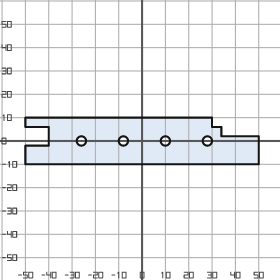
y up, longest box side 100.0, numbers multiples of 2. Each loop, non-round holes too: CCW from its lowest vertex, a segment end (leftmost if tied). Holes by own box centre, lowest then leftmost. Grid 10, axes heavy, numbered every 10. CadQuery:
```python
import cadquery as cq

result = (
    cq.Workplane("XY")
    .moveTo(-50.0, -10.0)
    .lineTo(50.0, -10.0)
    .lineTo(50.0, 2.0)
    .lineTo(34.0, 2.0)
    .lineTo(34.0, 6.0)
    .lineTo(30.0, 6.0)
    .lineTo(30.0, 10.0)
    .lineTo(-50.0, 10.0)
    .lineTo(-50.0, 6.0)
    .lineTo(-40.0, 6.0)
    .lineTo(-40.0, -2.0)
    .lineTo(-50.0, -2.0)
    .close()
    .moveTo(-26.0, 0.0)
    .circle(2.0)
    .moveTo(-8.0, 0.0)
    .circle(2.0)
    .moveTo(10.0, 0.0)
    .circle(2.0)
    .moveTo(28.0, 0.0)
    .circle(2.0)
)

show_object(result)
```